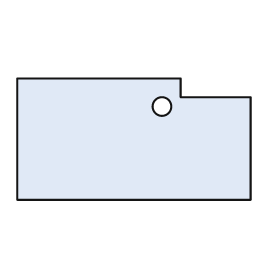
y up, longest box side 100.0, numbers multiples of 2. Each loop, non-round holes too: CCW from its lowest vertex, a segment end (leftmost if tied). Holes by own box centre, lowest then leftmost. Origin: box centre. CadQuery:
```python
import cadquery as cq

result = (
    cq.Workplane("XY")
    .moveTo(-50.0, -26.0)
    .lineTo(50.0, -26.0)
    .lineTo(50.0, 18.0)
    .lineTo(20.0, 18.0)
    .lineTo(20.0, 26.0)
    .lineTo(-50.0, 26.0)
    .close()
    .moveTo(12.0, 14.0)
    .circle(4.0)
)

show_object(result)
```